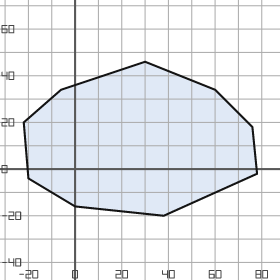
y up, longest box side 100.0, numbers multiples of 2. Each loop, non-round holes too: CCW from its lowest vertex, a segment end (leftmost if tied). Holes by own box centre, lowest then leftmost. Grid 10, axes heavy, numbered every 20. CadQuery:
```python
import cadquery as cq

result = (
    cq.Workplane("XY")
    .moveTo(38.0, -20.0)
    .lineTo(78.0, -2.0)
    .lineTo(76.0, 18.0)
    .lineTo(60.0, 34.0)
    .lineTo(30.0, 46.0)
    .lineTo(-6.0, 34.0)
    .lineTo(-22.0, 20.0)
    .lineTo(-20.0, -4.0)
    .lineTo(0.0, -16.0)
    .close()
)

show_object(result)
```